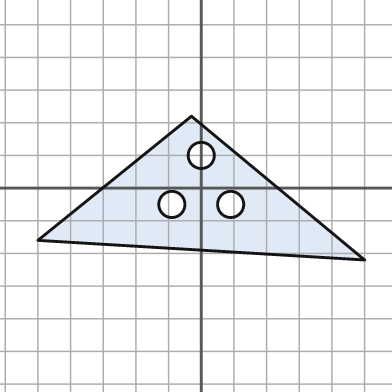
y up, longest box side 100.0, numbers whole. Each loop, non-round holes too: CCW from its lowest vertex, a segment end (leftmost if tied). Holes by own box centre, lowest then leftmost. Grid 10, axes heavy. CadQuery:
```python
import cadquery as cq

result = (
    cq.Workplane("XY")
    .moveTo(50.0, -22.0)
    .lineTo(-3.0, 22.0)
    .lineTo(-50.0, -16.0)
    .close()
    .moveTo(-9.0, -5.0)
    .circle(4.0)
    .moveTo(9.0, -5.0)
    .circle(4.0)
    .moveTo(0.0, 10.0)
    .circle(4.0)
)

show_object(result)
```